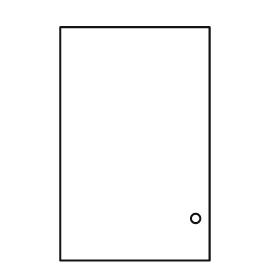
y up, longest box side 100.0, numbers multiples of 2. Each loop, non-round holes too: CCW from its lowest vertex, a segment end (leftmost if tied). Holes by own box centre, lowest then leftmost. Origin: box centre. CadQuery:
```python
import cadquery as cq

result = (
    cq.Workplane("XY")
    .moveTo(-32.0, -50.0)
    .lineTo(32.0, -50.0)
    .lineTo(32.0, 50.0)
    .lineTo(-32.0, 50.0)
    .close()
    .moveTo(26.0, -32.0)
    .circle(2.0)
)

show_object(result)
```